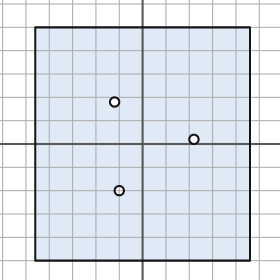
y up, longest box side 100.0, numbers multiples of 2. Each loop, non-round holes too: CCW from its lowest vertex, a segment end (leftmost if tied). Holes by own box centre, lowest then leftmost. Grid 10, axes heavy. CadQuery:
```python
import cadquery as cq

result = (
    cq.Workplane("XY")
    .moveTo(-46.0, -50.0)
    .lineTo(46.0, -50.0)
    .lineTo(46.0, 50.0)
    .lineTo(-46.0, 50.0)
    .close()
    .moveTo(-10.0, -20.0)
    .circle(2.0)
    .moveTo(22.0, 2.0)
    .circle(2.0)
    .moveTo(-12.0, 18.0)
    .circle(2.0)
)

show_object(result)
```